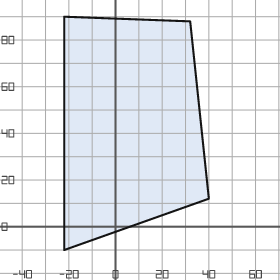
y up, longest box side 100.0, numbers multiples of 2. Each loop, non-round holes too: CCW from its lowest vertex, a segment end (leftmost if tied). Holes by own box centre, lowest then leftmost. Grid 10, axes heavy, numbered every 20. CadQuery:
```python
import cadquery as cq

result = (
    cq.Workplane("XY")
    .moveTo(-22.0, -10.0)
    .lineTo(40.0, 12.0)
    .lineTo(32.0, 88.0)
    .lineTo(-22.0, 90.0)
    .close()
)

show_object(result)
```